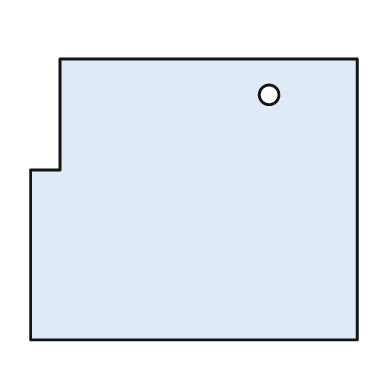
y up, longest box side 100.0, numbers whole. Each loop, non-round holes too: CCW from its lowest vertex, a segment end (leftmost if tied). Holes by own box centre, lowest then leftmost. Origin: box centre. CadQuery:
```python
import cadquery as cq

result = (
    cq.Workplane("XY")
    .moveTo(-50.0, -43.0)
    .lineTo(50.0, -43.0)
    .lineTo(50.0, 43.0)
    .lineTo(-41.0, 43.0)
    .lineTo(-41.0, 9.0)
    .lineTo(-50.0, 9.0)
    .close()
    .moveTo(23.0, 32.0)
    .circle(3.0)
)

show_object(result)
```